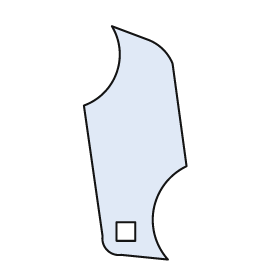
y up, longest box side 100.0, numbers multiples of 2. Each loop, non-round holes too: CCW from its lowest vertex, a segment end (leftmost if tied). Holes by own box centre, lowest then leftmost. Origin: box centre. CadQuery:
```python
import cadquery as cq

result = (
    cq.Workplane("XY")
    .moveTo(14.0, -50.0)
    .threePointArc((8.0, -28.0), (22.0, -10.0))
    .lineTo(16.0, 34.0)
    .threePointArc((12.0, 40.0), (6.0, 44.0))
    .lineTo(-10.0, 50.0)
    .threePointArc((-8.0, 30.0), (-22.0, 16.0))
    .lineTo(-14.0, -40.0)
    .threePointArc((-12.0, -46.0), (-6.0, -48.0))
    .close()
    .moveTo(-8.0, -42.0)
    .lineTo(0.0, -42.0)
    .lineTo(0.0, -34.0)
    .lineTo(-8.0, -34.0)
    .close()
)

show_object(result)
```